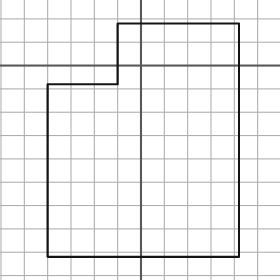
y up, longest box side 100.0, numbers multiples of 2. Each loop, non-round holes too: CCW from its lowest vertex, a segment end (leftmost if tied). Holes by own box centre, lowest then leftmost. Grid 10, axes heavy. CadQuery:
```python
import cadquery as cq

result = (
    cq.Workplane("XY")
    .moveTo(-40.0, -82.0)
    .lineTo(42.0, -82.0)
    .lineTo(42.0, 18.0)
    .lineTo(-10.0, 18.0)
    .lineTo(-10.0, -8.0)
    .lineTo(-40.0, -8.0)
    .close()
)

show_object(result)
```